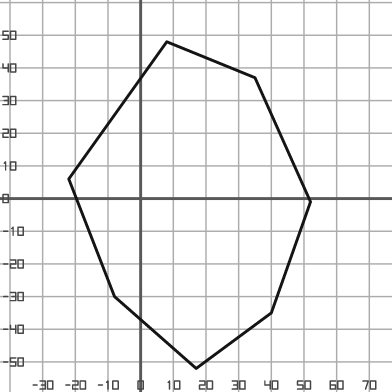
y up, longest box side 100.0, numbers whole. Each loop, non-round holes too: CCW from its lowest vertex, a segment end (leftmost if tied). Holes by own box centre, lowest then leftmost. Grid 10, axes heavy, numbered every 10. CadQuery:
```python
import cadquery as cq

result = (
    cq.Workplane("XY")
    .moveTo(17.0, -52.0)
    .lineTo(40.0, -35.0)
    .lineTo(52.0, -1.0)
    .lineTo(35.0, 37.0)
    .lineTo(8.0, 48.0)
    .lineTo(-22.0, 6.0)
    .lineTo(-8.0, -30.0)
    .close()
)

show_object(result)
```